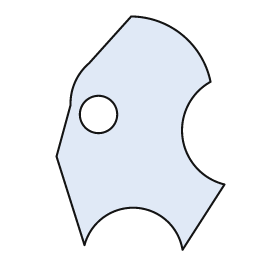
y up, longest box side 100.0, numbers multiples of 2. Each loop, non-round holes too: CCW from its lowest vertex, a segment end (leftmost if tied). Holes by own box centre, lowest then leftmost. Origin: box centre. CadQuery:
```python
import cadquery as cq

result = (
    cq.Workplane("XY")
    .moveTo(18.0, -50.0)
    .lineTo(36.0, -22.0)
    .threePointArc((18.0, -2.0), (30.0, 22.0))
    .threePointArc((18.0, 42.0), (-4.0, 50.0))
    .lineTo(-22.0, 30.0)
    .threePointArc((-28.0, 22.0), (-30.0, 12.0))
    .lineTo(-36.0, -10.0)
    .lineTo(-24.0, -48.0)
    .threePointArc((-2.0, -32.0), (18.0, -50.0))
    .close()
    .moveTo(-18.0, 8.0)
    .circle(8.0)
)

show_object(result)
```